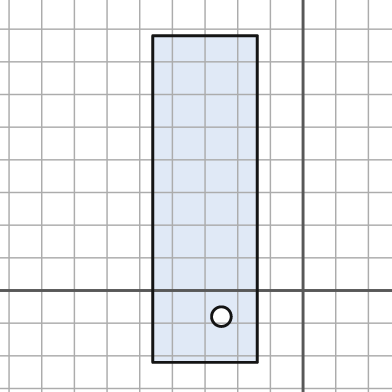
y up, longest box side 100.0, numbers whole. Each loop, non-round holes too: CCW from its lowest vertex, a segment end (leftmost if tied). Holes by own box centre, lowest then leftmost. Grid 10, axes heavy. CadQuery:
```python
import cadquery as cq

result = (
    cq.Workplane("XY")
    .moveTo(-46.0, -22.0)
    .lineTo(-14.0, -22.0)
    .lineTo(-14.0, 78.0)
    .lineTo(-46.0, 78.0)
    .close()
    .moveTo(-25.0, -8.0)
    .circle(3.0)
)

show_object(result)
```